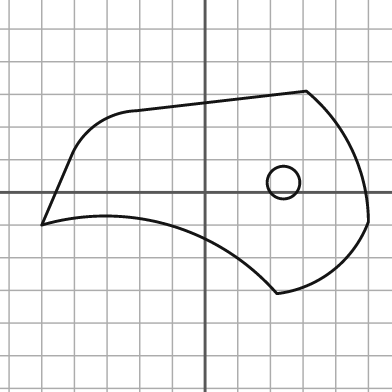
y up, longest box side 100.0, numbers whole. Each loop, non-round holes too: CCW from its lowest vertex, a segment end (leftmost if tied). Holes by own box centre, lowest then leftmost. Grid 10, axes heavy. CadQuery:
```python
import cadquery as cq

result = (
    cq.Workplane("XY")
    .moveTo(22.0, -31.0)
    .threePointArc((39.0, -24.0), (50.0, -9.0))
    .threePointArc((45.0, 13.0), (31.0, 31.0))
    .lineTo(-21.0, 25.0)
    .threePointArc((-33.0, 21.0), (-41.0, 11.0))
    .lineTo(-50.0, -10.0)
    .threePointArc((-11.0, -10.0), (22.0, -31.0))
    .close()
    .moveTo(24.0, 3.0)
    .circle(5.0)
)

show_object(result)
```